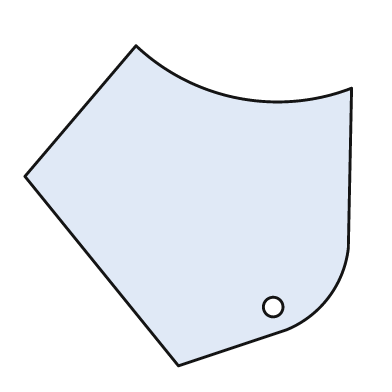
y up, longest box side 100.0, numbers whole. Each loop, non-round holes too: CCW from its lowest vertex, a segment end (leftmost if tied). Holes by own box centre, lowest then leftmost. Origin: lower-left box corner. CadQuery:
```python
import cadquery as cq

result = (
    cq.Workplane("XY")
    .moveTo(47.0, 0.0)
    .lineTo(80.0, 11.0)
    .threePointArc((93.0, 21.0), (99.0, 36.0))
    .lineTo(100.0, 85.0)
    .threePointArc((65.0, 82.0), (34.0, 98.0))
    .lineTo(0.0, 58.0)
    .close()
    .moveTo(76.0, 18.0)
    .circle(3.0)
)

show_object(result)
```